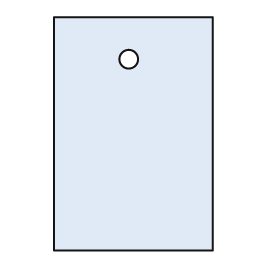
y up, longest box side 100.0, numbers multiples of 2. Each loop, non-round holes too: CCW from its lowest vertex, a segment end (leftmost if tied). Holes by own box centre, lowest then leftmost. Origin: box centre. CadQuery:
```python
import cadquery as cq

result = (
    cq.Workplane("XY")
    .moveTo(-34.0, -50.0)
    .lineTo(34.0, -50.0)
    .lineTo(34.0, 50.0)
    .lineTo(-34.0, 50.0)
    .close()
    .moveTo(-2.0, 32.0)
    .circle(4.0)
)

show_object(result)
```